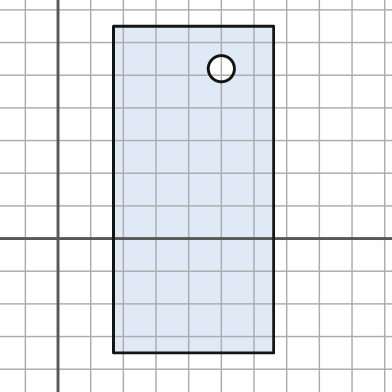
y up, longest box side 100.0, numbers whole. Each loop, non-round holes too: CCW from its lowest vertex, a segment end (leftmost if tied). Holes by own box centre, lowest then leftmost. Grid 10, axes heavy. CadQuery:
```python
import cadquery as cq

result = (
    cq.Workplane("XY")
    .moveTo(17.0, -35.0)
    .lineTo(66.0, -35.0)
    .lineTo(66.0, 65.0)
    .lineTo(17.0, 65.0)
    .close()
    .moveTo(50.0, 52.0)
    .circle(4.0)
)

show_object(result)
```